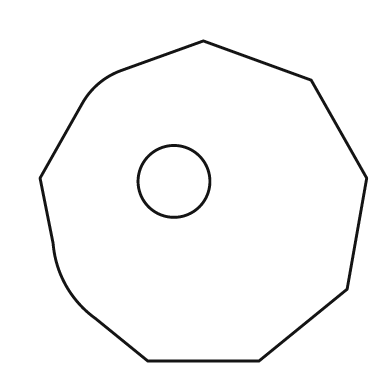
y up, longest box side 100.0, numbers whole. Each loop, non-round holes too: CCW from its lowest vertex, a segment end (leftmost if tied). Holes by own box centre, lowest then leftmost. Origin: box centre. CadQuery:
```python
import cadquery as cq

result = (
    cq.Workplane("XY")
    .moveTo(-17.0, -49.0)
    .lineTo(17.0, -49.0)
    .lineTo(44.0, -27.0)
    .lineTo(50.0, 7.0)
    .lineTo(33.0, 37.0)
    .lineTo(0.0, 49.0)
    .lineTo(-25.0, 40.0)
    .threePointArc((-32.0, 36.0), (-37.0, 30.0))
    .lineTo(-50.0, 7.0)
    .lineTo(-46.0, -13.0)
    .threePointArc((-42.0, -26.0), (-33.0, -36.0))
    .close()
    .moveTo(-9.0, 6.0)
    .circle(11.0)
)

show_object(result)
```